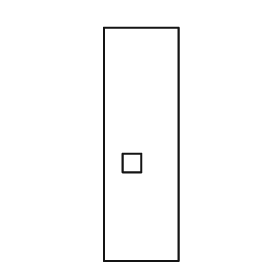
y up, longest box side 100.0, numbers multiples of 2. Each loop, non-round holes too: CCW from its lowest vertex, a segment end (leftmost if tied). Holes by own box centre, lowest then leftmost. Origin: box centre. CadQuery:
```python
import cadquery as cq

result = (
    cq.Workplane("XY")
    .moveTo(-16.0, -50.0)
    .lineTo(16.0, -50.0)
    .lineTo(16.0, 50.0)
    .lineTo(-16.0, 50.0)
    .close()
    .moveTo(-8.0, -12.0)
    .lineTo(0.0, -12.0)
    .lineTo(0.0, -4.0)
    .lineTo(-8.0, -4.0)
    .close()
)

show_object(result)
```